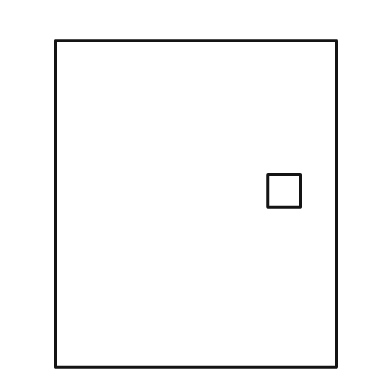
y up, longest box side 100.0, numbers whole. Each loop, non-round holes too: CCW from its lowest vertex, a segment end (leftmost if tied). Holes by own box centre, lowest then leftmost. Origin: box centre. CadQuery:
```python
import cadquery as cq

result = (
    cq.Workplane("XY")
    .moveTo(-43.0, -50.0)
    .lineTo(43.0, -50.0)
    .lineTo(43.0, 50.0)
    .lineTo(-43.0, 50.0)
    .close()
    .moveTo(22.0, -1.0)
    .lineTo(32.0, -1.0)
    .lineTo(32.0, 9.0)
    .lineTo(22.0, 9.0)
    .close()
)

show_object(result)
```